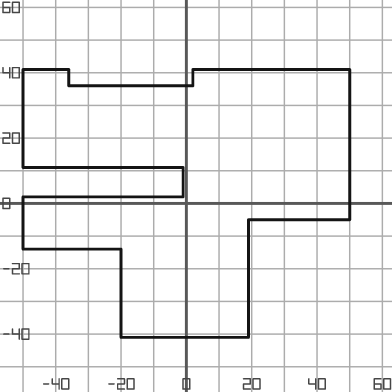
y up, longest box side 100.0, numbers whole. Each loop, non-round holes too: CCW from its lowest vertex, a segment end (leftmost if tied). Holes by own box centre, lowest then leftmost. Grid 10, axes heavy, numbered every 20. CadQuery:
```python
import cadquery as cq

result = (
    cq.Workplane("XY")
    .moveTo(-20.0, -41.0)
    .lineTo(19.0, -41.0)
    .lineTo(19.0, -5.0)
    .lineTo(50.0, -5.0)
    .lineTo(50.0, 41.0)
    .lineTo(2.0, 41.0)
    .lineTo(2.0, 36.0)
    .lineTo(-36.0, 36.0)
    .lineTo(-36.0, 41.0)
    .lineTo(-50.0, 41.0)
    .lineTo(-50.0, 11.0)
    .lineTo(-1.0, 11.0)
    .lineTo(-1.0, 2.0)
    .lineTo(-50.0, 2.0)
    .lineTo(-50.0, -14.0)
    .lineTo(-20.0, -14.0)
    .close()
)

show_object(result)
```